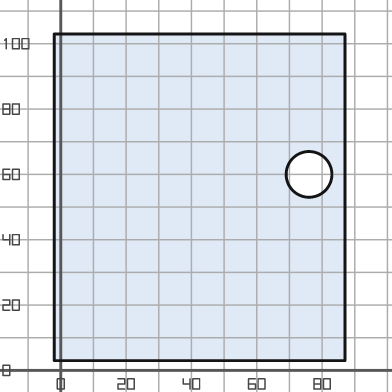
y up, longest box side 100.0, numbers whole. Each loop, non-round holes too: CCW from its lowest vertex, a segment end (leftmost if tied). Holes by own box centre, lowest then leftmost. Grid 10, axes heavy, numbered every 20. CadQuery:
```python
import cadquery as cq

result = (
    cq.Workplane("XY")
    .moveTo(-2.0, 3.0)
    .lineTo(87.0, 3.0)
    .lineTo(87.0, 103.0)
    .lineTo(-2.0, 103.0)
    .close()
    .moveTo(76.0, 60.0)
    .circle(7.0)
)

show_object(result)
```